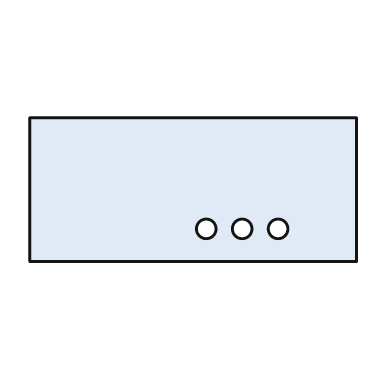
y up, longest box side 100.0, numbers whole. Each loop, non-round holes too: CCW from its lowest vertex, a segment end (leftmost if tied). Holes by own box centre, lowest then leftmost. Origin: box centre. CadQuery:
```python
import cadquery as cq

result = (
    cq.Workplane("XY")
    .moveTo(-50.0, -22.0)
    .lineTo(50.0, -22.0)
    .lineTo(50.0, 22.0)
    .lineTo(-50.0, 22.0)
    .close()
    .moveTo(4.0, -12.0)
    .circle(3.0)
    .moveTo(15.0, -12.0)
    .circle(3.0)
    .moveTo(26.0, -12.0)
    .circle(3.0)
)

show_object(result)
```